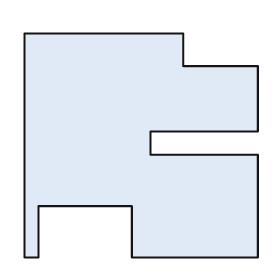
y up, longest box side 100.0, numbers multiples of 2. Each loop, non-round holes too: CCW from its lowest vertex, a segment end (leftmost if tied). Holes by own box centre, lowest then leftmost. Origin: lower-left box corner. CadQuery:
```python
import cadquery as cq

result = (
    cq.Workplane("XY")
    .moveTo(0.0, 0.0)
    .lineTo(6.0, 0.0)
    .lineTo(6.0, 22.0)
    .lineTo(46.0, 22.0)
    .lineTo(46.0, 0.0)
    .lineTo(100.0, 0.0)
    .lineTo(100.0, 44.0)
    .lineTo(54.0, 44.0)
    .lineTo(54.0, 54.0)
    .lineTo(100.0, 54.0)
    .lineTo(100.0, 82.0)
    .lineTo(68.0, 82.0)
    .lineTo(68.0, 96.0)
    .lineTo(0.0, 96.0)
    .close()
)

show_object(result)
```